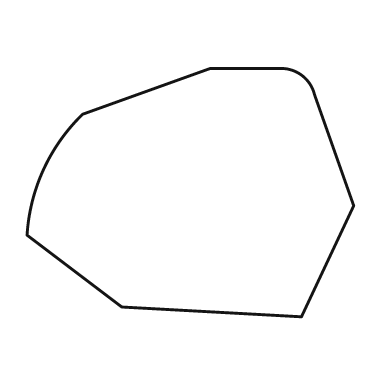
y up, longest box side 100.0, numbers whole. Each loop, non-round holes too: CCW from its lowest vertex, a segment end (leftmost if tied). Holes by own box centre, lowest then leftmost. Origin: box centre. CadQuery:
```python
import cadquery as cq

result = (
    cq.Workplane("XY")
    .moveTo(34.0, -38.0)
    .lineTo(50.0, -4.0)
    .lineTo(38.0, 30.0)
    .threePointArc((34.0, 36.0), (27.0, 38.0))
    .lineTo(6.0, 38.0)
    .lineTo(-33.0, 24.0)
    .threePointArc((-45.0, 7.0), (-50.0, -13.0))
    .lineTo(-21.0, -35.0)
    .close()
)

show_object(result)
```